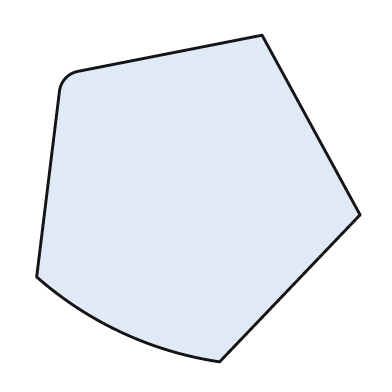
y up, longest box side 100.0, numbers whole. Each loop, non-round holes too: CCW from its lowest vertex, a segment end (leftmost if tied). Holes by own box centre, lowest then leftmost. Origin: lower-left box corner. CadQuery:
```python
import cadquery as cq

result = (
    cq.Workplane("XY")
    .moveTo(56.0, 0.0)
    .lineTo(99.0, 45.0)
    .lineTo(69.0, 100.0)
    .lineTo(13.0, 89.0)
    .threePointArc((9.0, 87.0), (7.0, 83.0))
    .lineTo(0.0, 26.0)
    .threePointArc((26.0, 9.0), (56.0, 0.0))
    .close()
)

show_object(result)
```